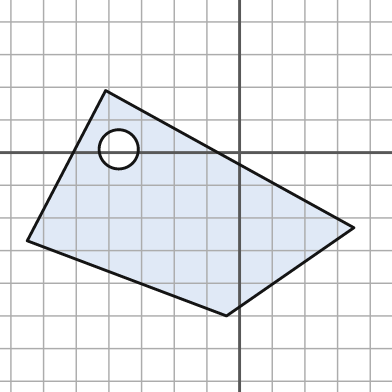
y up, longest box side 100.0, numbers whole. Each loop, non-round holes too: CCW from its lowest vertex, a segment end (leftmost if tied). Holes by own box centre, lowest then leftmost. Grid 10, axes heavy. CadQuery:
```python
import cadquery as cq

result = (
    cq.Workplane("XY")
    .moveTo(-4.0, -50.0)
    .lineTo(35.0, -23.0)
    .lineTo(-41.0, 19.0)
    .lineTo(-65.0, -27.0)
    .close()
    .moveTo(-37.0, 1.0)
    .circle(6.0)
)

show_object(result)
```